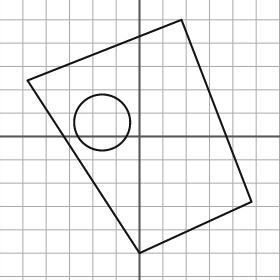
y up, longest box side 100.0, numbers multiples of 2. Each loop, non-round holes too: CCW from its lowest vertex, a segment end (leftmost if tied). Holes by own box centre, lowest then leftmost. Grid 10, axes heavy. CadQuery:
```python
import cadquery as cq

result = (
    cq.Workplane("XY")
    .moveTo(0.0, -50.0)
    .lineTo(48.0, -28.0)
    .lineTo(18.0, 50.0)
    .lineTo(-48.0, 24.0)
    .close()
    .moveTo(-16.0, 6.0)
    .circle(12.0)
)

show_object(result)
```